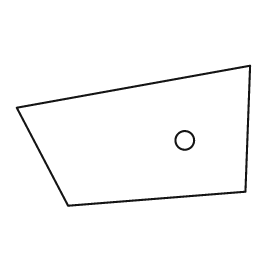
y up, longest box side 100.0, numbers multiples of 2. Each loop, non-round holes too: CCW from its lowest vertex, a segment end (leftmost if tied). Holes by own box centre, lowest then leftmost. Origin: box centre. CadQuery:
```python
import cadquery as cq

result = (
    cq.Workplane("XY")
    .moveTo(-28.0, -30.0)
    .lineTo(48.0, -24.0)
    .lineTo(50.0, 30.0)
    .lineTo(-50.0, 12.0)
    .close()
    .moveTo(22.0, -2.0)
    .circle(4.0)
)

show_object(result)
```